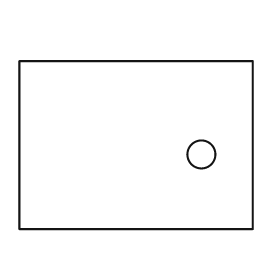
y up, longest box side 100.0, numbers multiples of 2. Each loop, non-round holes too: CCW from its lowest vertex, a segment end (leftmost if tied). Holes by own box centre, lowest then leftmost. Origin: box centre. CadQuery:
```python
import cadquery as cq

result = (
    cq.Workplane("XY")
    .moveTo(-50.0, -36.0)
    .lineTo(50.0, -36.0)
    .lineTo(50.0, 36.0)
    .lineTo(-50.0, 36.0)
    .close()
    .moveTo(28.0, -4.0)
    .circle(6.0)
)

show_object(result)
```